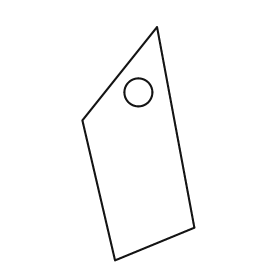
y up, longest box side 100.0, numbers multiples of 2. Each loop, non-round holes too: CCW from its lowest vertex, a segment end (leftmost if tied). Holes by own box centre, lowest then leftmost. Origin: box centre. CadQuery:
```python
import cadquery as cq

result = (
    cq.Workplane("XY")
    .moveTo(-10.0, -50.0)
    .lineTo(24.0, -36.0)
    .lineTo(8.0, 50.0)
    .lineTo(-24.0, 10.0)
    .close()
    .moveTo(0.0, 22.0)
    .circle(6.0)
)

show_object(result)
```